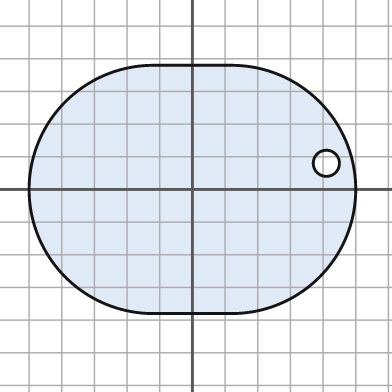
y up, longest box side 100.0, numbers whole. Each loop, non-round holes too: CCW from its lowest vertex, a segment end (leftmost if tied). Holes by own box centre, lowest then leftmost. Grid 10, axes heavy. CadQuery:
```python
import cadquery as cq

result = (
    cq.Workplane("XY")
    .moveTo(-12.0, -38.0)
    .lineTo(12.0, -38.0)
    .threePointArc((50.0, 0.0), (12.0, 38.0))
    .lineTo(-12.0, 38.0)
    .threePointArc((-50.0, 0.0), (-12.0, -38.0))
    .close()
    .moveTo(41.0, 8.0)
    .circle(4.0)
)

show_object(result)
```